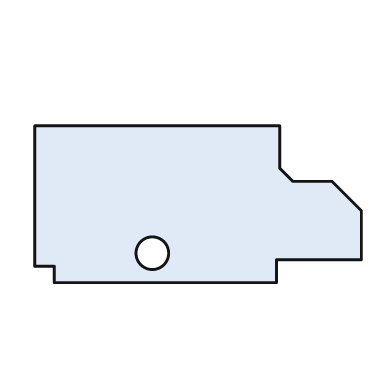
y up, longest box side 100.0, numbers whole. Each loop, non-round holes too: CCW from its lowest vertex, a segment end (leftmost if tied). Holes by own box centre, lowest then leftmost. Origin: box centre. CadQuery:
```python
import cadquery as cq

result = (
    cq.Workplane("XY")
    .moveTo(-44.0, -24.0)
    .lineTo(24.0, -24.0)
    .lineTo(24.0, -17.0)
    .lineTo(50.0, -17.0)
    .lineTo(50.0, -2.0)
    .lineTo(41.0, 7.0)
    .lineTo(29.0, 7.0)
    .lineTo(25.0, 11.0)
    .lineTo(25.0, 24.0)
    .lineTo(-50.0, 24.0)
    .lineTo(-50.0, -19.0)
    .lineTo(-44.0, -19.0)
    .close()
    .moveTo(-14.0, -15.0)
    .circle(5.0)
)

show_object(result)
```